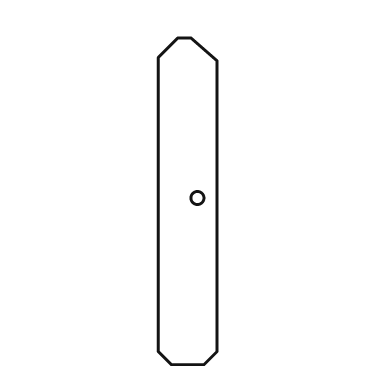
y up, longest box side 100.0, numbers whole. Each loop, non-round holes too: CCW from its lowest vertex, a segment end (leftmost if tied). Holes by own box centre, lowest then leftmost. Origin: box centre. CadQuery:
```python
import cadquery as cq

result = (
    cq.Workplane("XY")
    .moveTo(-5.0, -50.0)
    .lineTo(5.0, -50.0)
    .lineTo(9.0, -46.0)
    .lineTo(9.0, 43.0)
    .lineTo(1.0, 50.0)
    .lineTo(-3.0, 50.0)
    .lineTo(-9.0, 44.0)
    .lineTo(-9.0, -46.0)
    .close()
    .moveTo(3.0, 1.0)
    .circle(2.0)
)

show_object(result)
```